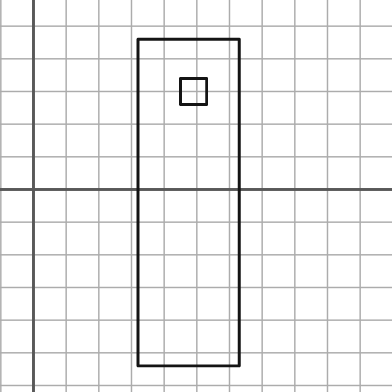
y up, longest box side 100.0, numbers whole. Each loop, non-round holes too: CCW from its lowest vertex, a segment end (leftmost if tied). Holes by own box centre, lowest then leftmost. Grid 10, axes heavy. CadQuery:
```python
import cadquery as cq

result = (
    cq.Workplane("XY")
    .moveTo(32.0, -54.0)
    .lineTo(63.0, -54.0)
    .lineTo(63.0, 46.0)
    .lineTo(32.0, 46.0)
    .close()
    .moveTo(45.0, 26.0)
    .lineTo(53.0, 26.0)
    .lineTo(53.0, 34.0)
    .lineTo(45.0, 34.0)
    .close()
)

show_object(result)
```